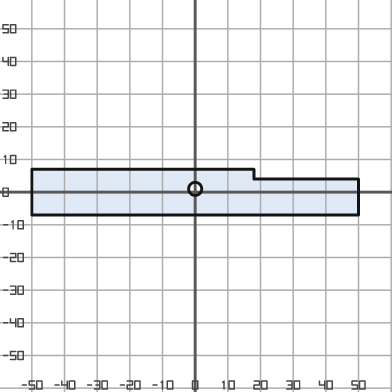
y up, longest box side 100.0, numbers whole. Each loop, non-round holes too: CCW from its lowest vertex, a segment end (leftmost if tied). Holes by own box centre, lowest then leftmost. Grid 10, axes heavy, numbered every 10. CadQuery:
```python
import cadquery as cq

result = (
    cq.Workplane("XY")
    .moveTo(-50.0, -7.0)
    .lineTo(50.0, -7.0)
    .lineTo(50.0, 4.0)
    .lineTo(18.0, 4.0)
    .lineTo(18.0, 7.0)
    .lineTo(-50.0, 7.0)
    .close()
    .moveTo(0.0, 1.0)
    .circle(2.0)
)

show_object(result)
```